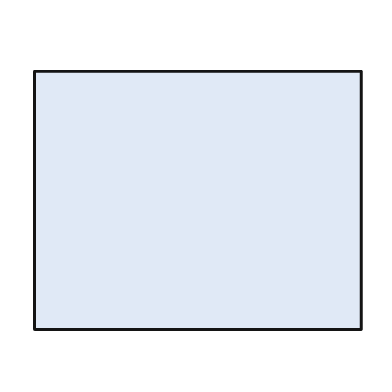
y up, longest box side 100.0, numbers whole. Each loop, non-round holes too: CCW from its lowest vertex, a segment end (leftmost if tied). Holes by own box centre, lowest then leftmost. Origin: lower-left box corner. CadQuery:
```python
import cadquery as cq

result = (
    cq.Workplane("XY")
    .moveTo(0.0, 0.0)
    .lineTo(100.0, 0.0)
    .lineTo(100.0, 79.0)
    .lineTo(0.0, 79.0)
    .close()
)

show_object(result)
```